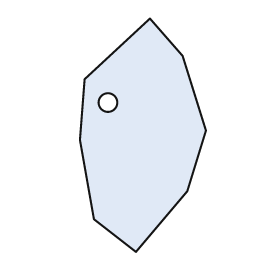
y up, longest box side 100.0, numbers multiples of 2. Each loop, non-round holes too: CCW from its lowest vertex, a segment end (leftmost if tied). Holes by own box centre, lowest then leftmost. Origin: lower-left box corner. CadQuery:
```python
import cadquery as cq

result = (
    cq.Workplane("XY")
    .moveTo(24.0, 0.0)
    .lineTo(46.0, 26.0)
    .lineTo(54.0, 52.0)
    .lineTo(44.0, 84.0)
    .lineTo(30.0, 100.0)
    .lineTo(2.0, 74.0)
    .lineTo(0.0, 48.0)
    .lineTo(6.0, 14.0)
    .close()
    .moveTo(12.0, 64.0)
    .circle(4.0)
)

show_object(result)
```